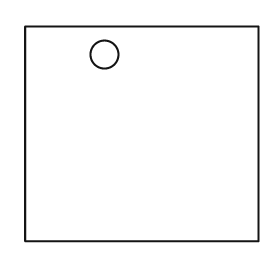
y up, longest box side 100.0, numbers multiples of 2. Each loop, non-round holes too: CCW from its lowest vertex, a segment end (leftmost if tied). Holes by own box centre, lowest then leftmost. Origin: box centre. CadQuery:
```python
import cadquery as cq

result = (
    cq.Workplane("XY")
    .moveTo(-50.0, -46.0)
    .lineTo(50.0, -46.0)
    .lineTo(50.0, 46.0)
    .lineTo(-50.0, 46.0)
    .close()
    .moveTo(-16.0, 34.0)
    .circle(6.0)
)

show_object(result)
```